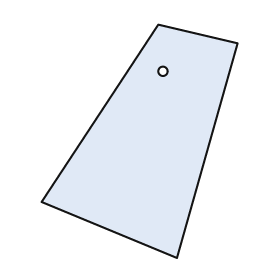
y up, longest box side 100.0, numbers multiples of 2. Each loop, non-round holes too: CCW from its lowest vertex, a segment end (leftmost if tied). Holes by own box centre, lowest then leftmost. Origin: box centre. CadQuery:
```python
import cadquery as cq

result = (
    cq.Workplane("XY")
    .moveTo(16.0, -50.0)
    .lineTo(42.0, 42.0)
    .lineTo(8.0, 50.0)
    .lineTo(-42.0, -26.0)
    .close()
    .moveTo(10.0, 30.0)
    .circle(2.0)
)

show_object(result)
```